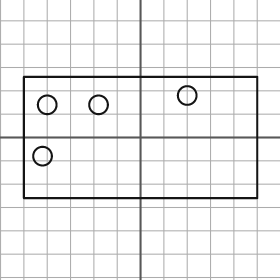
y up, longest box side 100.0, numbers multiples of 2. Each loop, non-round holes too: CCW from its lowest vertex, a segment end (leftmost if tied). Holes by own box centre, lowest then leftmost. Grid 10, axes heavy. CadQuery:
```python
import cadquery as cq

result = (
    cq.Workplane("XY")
    .moveTo(-50.0, -26.0)
    .lineTo(50.0, -26.0)
    .lineTo(50.0, 26.0)
    .lineTo(-50.0, 26.0)
    .close()
    .moveTo(-42.0, -8.0)
    .circle(4.0)
    .moveTo(-40.0, 14.0)
    .circle(4.0)
    .moveTo(-18.0, 14.0)
    .circle(4.0)
    .moveTo(20.0, 18.0)
    .circle(4.0)
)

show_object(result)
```